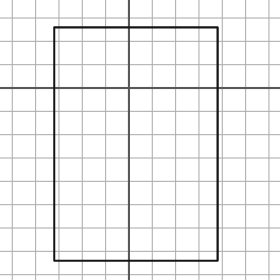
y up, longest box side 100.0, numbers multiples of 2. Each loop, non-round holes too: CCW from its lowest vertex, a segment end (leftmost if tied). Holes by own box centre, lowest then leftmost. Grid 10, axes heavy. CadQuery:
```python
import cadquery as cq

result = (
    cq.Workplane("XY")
    .moveTo(-32.0, -74.0)
    .lineTo(38.0, -74.0)
    .lineTo(38.0, 26.0)
    .lineTo(-32.0, 26.0)
    .close()
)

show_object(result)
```